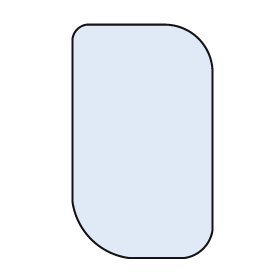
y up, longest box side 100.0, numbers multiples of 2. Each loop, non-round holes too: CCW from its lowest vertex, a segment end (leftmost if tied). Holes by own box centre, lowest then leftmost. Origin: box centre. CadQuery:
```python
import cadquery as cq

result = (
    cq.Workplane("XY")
    .moveTo(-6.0, -50.0)
    .lineTo(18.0, -50.0)
    .threePointArc((26.0, -46.0), (30.0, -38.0))
    .lineTo(30.0, 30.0)
    .threePointArc((24.0, 44.0), (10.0, 50.0))
    .lineTo(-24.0, 50.0)
    .threePointArc((-28.0, 48.0), (-30.0, 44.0))
    .lineTo(-30.0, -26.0)
    .threePointArc((-22.0, -42.0), (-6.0, -50.0))
    .close()
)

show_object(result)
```